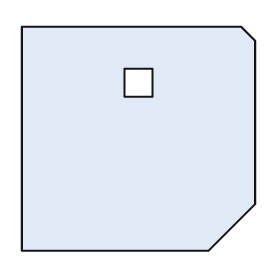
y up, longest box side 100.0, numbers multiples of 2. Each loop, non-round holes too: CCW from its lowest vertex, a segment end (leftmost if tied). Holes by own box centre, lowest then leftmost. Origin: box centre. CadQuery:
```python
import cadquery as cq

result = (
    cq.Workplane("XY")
    .moveTo(-50.0, -48.0)
    .lineTo(30.0, -48.0)
    .lineTo(50.0, -28.0)
    .lineTo(50.0, 42.0)
    .lineTo(44.0, 48.0)
    .lineTo(-50.0, 48.0)
    .close()
    .moveTo(-6.0, 18.0)
    .lineTo(6.0, 18.0)
    .lineTo(6.0, 30.0)
    .lineTo(-6.0, 30.0)
    .close()
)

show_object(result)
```